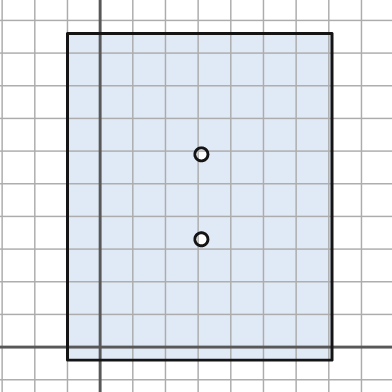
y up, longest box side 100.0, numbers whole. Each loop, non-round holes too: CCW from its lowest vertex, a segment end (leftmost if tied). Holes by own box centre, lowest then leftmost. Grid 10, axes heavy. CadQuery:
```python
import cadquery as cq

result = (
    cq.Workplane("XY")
    .moveTo(-10.0, -4.0)
    .lineTo(71.0, -4.0)
    .lineTo(71.0, 96.0)
    .lineTo(-10.0, 96.0)
    .close()
    .moveTo(31.0, 33.0)
    .circle(2.0)
    .moveTo(31.0, 59.0)
    .circle(2.0)
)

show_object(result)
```